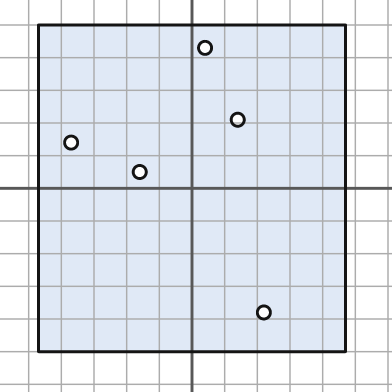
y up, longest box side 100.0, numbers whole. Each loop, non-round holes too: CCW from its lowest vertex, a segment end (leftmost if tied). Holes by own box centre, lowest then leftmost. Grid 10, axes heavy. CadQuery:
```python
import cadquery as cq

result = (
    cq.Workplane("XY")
    .moveTo(-47.0, -50.0)
    .lineTo(47.0, -50.0)
    .lineTo(47.0, 50.0)
    .lineTo(-47.0, 50.0)
    .close()
    .moveTo(22.0, -38.0)
    .circle(2.0)
    .moveTo(-16.0, 5.0)
    .circle(2.0)
    .moveTo(-37.0, 14.0)
    .circle(2.0)
    .moveTo(14.0, 21.0)
    .circle(2.0)
    .moveTo(4.0, 43.0)
    .circle(2.0)
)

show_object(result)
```